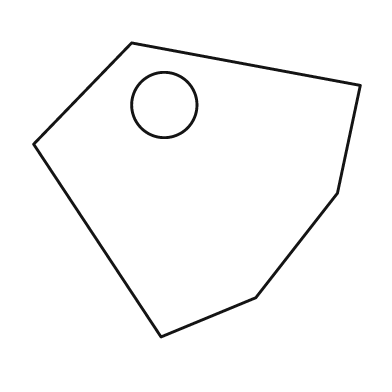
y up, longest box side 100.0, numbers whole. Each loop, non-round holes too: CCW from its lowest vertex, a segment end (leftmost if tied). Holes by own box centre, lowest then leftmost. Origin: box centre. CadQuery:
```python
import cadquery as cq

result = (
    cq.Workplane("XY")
    .moveTo(-11.0, -45.0)
    .lineTo(18.0, -33.0)
    .lineTo(43.0, -1.0)
    .lineTo(50.0, 32.0)
    .lineTo(-20.0, 45.0)
    .lineTo(-50.0, 14.0)
    .close()
    .moveTo(-10.0, 26.0)
    .circle(10.0)
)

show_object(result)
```